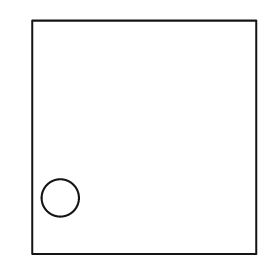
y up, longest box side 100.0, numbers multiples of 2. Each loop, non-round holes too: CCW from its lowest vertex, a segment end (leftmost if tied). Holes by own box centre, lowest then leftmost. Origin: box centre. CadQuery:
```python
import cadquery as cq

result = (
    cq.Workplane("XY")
    .moveTo(-48.0, -50.0)
    .lineTo(48.0, -50.0)
    .lineTo(48.0, 50.0)
    .lineTo(-48.0, 50.0)
    .close()
    .moveTo(-36.0, -26.0)
    .circle(8.0)
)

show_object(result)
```